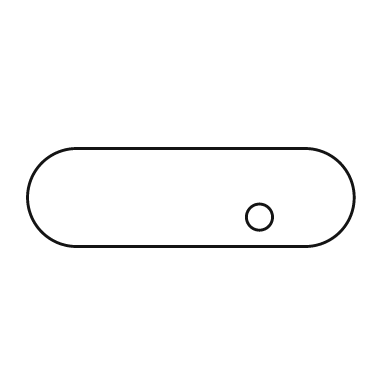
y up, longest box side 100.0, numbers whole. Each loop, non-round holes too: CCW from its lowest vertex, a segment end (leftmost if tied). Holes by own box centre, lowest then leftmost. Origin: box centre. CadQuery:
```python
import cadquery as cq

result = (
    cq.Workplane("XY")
    .moveTo(-35.0, -15.0)
    .lineTo(35.0, -15.0)
    .threePointArc((50.0, 0.0), (35.0, 15.0))
    .lineTo(-35.0, 15.0)
    .threePointArc((-50.0, 0.0), (-35.0, -15.0))
    .close()
    .moveTo(21.0, -6.0)
    .circle(4.0)
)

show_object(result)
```